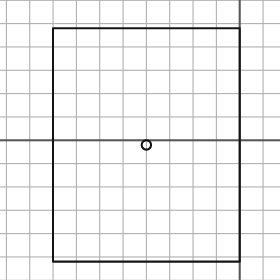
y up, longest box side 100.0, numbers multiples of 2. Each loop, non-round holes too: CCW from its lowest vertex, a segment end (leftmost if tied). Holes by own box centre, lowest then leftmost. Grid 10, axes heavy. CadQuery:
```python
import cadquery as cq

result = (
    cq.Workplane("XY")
    .moveTo(-80.0, -52.0)
    .lineTo(0.0, -52.0)
    .lineTo(0.0, 48.0)
    .lineTo(-80.0, 48.0)
    .close()
    .moveTo(-40.0, -2.0)
    .circle(2.0)
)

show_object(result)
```